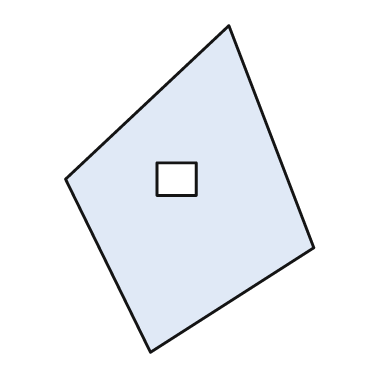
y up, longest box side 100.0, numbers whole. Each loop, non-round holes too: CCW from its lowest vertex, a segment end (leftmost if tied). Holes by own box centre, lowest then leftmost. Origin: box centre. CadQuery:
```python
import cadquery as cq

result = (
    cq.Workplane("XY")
    .moveTo(-12.0, -50.0)
    .lineTo(38.0, -18.0)
    .lineTo(12.0, 50.0)
    .lineTo(-38.0, 3.0)
    .close()
    .moveTo(-10.0, -2.0)
    .lineTo(2.0, -2.0)
    .lineTo(2.0, 8.0)
    .lineTo(-10.0, 8.0)
    .close()
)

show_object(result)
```